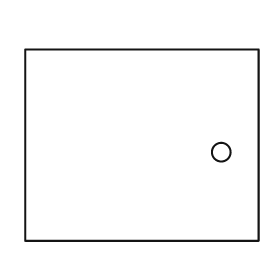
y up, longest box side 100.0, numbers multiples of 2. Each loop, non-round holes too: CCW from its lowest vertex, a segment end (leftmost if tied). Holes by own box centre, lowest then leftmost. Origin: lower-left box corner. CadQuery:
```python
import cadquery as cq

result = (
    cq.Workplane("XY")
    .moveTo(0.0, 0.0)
    .lineTo(100.0, 0.0)
    .lineTo(100.0, 82.0)
    .lineTo(0.0, 82.0)
    .close()
    .moveTo(84.0, 38.0)
    .circle(4.0)
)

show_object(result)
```